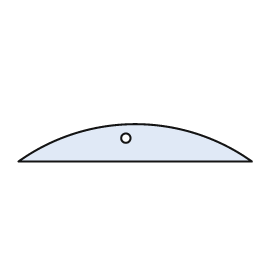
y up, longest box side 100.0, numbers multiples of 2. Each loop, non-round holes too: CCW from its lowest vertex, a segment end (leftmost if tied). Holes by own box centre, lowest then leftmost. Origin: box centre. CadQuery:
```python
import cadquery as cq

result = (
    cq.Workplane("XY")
    .moveTo(-50.0, -8.0)
    .lineTo(50.0, -8.0)
    .threePointArc((0.0, 8.0), (-50.0, -8.0))
    .close()
    .moveTo(-4.0, 2.0)
    .circle(2.0)
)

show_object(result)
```